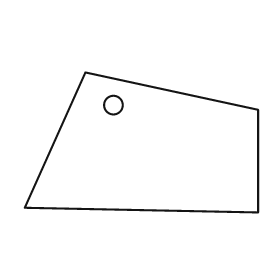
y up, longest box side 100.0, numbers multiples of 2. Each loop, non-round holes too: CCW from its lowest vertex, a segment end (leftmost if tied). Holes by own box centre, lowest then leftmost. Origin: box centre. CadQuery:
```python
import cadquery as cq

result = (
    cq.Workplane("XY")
    .moveTo(50.0, -30.0)
    .lineTo(50.0, 14.0)
    .lineTo(-24.0, 30.0)
    .lineTo(-50.0, -28.0)
    .close()
    .moveTo(-12.0, 16.0)
    .circle(4.0)
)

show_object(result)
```